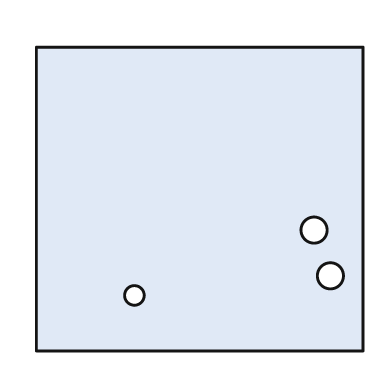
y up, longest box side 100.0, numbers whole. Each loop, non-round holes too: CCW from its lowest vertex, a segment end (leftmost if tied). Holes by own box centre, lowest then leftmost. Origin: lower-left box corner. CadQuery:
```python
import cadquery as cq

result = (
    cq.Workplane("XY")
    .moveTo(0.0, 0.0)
    .lineTo(100.0, 0.0)
    .lineTo(100.0, 93.0)
    .lineTo(0.0, 93.0)
    .close()
    .moveTo(30.0, 17.0)
    .circle(3.0)
    .moveTo(90.0, 23.0)
    .circle(4.0)
    .moveTo(85.0, 37.0)
    .circle(4.0)
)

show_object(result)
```